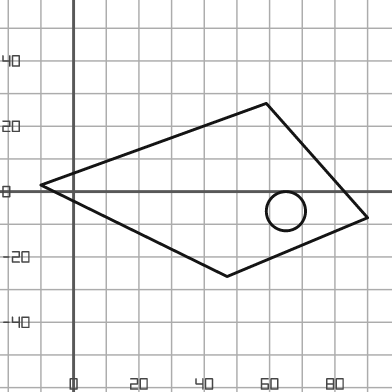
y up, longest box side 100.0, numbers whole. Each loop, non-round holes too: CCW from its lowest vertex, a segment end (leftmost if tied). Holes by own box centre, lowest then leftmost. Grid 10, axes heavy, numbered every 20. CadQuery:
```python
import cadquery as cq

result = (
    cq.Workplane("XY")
    .moveTo(47.0, -26.0)
    .lineTo(90.0, -8.0)
    .lineTo(59.0, 27.0)
    .lineTo(-10.0, 2.0)
    .close()
    .moveTo(65.0, -6.0)
    .circle(6.0)
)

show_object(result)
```